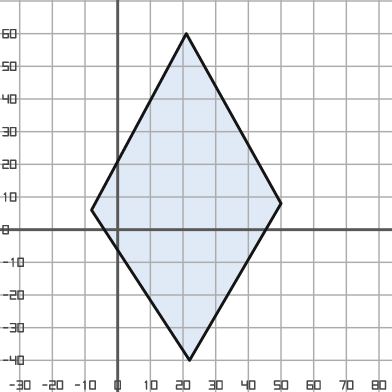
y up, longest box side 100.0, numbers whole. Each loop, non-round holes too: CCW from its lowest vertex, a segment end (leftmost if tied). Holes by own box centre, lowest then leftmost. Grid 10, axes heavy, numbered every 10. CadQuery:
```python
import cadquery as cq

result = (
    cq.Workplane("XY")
    .moveTo(22.0, -40.0)
    .lineTo(50.0, 8.0)
    .lineTo(21.0, 60.0)
    .lineTo(-8.0, 6.0)
    .close()
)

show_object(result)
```